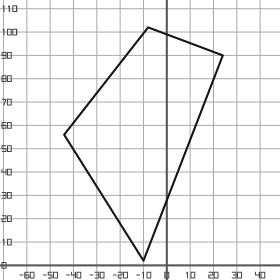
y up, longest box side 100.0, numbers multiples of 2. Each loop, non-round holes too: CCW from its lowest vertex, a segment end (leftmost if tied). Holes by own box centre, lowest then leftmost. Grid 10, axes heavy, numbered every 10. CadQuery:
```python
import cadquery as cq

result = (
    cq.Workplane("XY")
    .moveTo(-10.0, 2.0)
    .lineTo(24.0, 90.0)
    .lineTo(-8.0, 102.0)
    .lineTo(-44.0, 56.0)
    .close()
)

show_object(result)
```